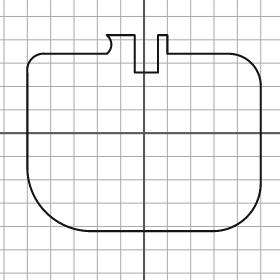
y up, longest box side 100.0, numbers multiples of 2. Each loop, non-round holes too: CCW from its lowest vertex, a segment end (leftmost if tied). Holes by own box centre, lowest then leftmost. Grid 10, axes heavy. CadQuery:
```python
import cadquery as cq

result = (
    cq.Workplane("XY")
    .moveTo(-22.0, -42.0)
    .lineTo(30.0, -42.0)
    .threePointArc((44.0, -36.0), (50.0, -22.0))
    .lineTo(50.0, 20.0)
    .threePointArc((46.0, 30.0), (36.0, 34.0))
    .lineTo(10.0, 34.0)
    .lineTo(10.0, 42.0)
    .lineTo(6.0, 42.0)
    .lineTo(6.0, 26.0)
    .lineTo(-4.0, 26.0)
    .lineTo(-4.0, 42.0)
    .lineTo(-16.0, 42.0)
    .threePointArc((-14.0, 38.0), (-16.0, 34.0))
    .lineTo(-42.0, 34.0)
    .threePointArc((-48.0, 32.0), (-50.0, 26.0))
    .lineTo(-50.0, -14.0)
    .threePointArc((-42.0, -34.0), (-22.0, -42.0))
    .close()
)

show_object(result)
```